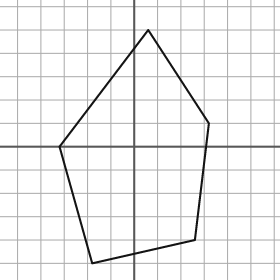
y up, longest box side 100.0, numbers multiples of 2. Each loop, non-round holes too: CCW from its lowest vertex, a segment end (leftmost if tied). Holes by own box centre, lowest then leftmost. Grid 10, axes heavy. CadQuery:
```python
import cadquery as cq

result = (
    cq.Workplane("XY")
    .moveTo(-18.0, -50.0)
    .lineTo(26.0, -40.0)
    .lineTo(32.0, 10.0)
    .lineTo(6.0, 50.0)
    .lineTo(-32.0, 0.0)
    .close()
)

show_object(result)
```